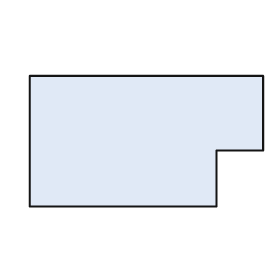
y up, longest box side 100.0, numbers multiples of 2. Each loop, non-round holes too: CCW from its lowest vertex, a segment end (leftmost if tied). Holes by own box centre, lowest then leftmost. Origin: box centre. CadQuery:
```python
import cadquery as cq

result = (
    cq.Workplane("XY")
    .moveTo(-50.0, -28.0)
    .lineTo(30.0, -28.0)
    .lineTo(30.0, -4.0)
    .lineTo(50.0, -4.0)
    .lineTo(50.0, 28.0)
    .lineTo(-50.0, 28.0)
    .close()
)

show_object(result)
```